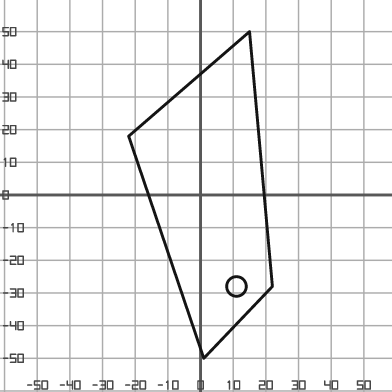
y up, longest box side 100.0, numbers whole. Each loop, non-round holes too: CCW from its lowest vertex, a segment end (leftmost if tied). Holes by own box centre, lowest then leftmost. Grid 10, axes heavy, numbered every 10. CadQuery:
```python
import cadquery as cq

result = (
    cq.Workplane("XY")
    .moveTo(1.0, -50.0)
    .lineTo(22.0, -28.0)
    .lineTo(15.0, 50.0)
    .lineTo(-22.0, 18.0)
    .close()
    .moveTo(11.0, -28.0)
    .circle(3.0)
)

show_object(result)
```